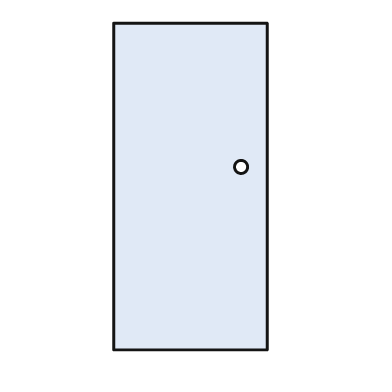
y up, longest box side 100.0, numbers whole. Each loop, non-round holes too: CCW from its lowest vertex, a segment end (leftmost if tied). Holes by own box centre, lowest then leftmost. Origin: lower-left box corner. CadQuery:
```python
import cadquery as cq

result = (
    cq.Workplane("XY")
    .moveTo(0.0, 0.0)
    .lineTo(47.0, 0.0)
    .lineTo(47.0, 100.0)
    .lineTo(0.0, 100.0)
    .close()
    .moveTo(39.0, 56.0)
    .circle(2.0)
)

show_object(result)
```